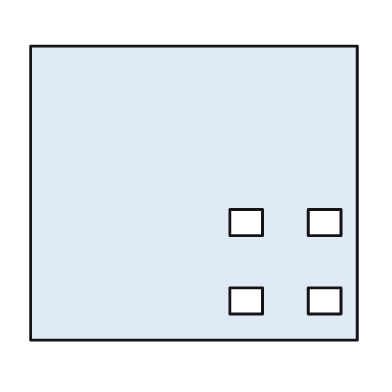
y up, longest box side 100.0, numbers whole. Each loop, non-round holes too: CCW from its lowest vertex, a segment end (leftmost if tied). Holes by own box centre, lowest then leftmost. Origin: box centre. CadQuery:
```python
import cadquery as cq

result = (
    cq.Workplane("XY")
    .moveTo(-50.0, -45.0)
    .lineTo(50.0, -45.0)
    .lineTo(50.0, 45.0)
    .lineTo(-50.0, 45.0)
    .close()
    .moveTo(11.0, -37.0)
    .lineTo(21.0, -37.0)
    .lineTo(21.0, -29.0)
    .lineTo(11.0, -29.0)
    .close()
    .moveTo(35.0, -37.0)
    .lineTo(45.0, -37.0)
    .lineTo(45.0, -29.0)
    .lineTo(35.0, -29.0)
    .close()
    .moveTo(11.0, -13.0)
    .lineTo(21.0, -13.0)
    .lineTo(21.0, -5.0)
    .lineTo(11.0, -5.0)
    .close()
    .moveTo(35.0, -13.0)
    .lineTo(45.0, -13.0)
    .lineTo(45.0, -5.0)
    .lineTo(35.0, -5.0)
    .close()
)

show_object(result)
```